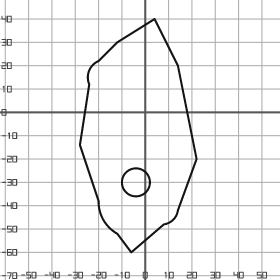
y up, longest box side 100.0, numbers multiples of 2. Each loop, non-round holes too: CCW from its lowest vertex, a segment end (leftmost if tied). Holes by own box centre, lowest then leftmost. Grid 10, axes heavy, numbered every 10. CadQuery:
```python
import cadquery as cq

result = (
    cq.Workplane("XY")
    .moveTo(-6.0, -60.0)
    .lineTo(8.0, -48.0)
    .threePointArc((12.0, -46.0), (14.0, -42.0))
    .lineTo(22.0, -20.0)
    .lineTo(14.0, 20.0)
    .lineTo(4.0, 40.0)
    .lineTo(-12.0, 30.0)
    .lineTo(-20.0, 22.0)
    .threePointArc((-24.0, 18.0), (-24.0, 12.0))
    .lineTo(-28.0, -14.0)
    .lineTo(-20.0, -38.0)
    .threePointArc((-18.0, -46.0), (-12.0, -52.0))
    .close()
    .moveTo(-4.0, -30.0)
    .circle(6.0)
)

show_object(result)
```